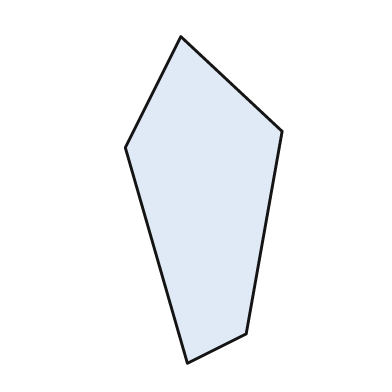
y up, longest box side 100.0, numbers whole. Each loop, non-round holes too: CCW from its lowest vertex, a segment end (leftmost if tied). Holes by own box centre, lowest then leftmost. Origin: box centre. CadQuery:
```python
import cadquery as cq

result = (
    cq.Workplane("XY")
    .moveTo(-5.0, -50.0)
    .lineTo(13.0, -41.0)
    .lineTo(24.0, 21.0)
    .lineTo(-7.0, 50.0)
    .lineTo(-24.0, 16.0)
    .close()
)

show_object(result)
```